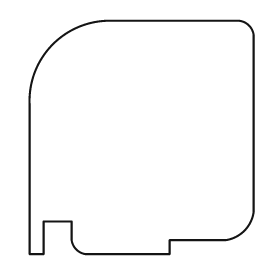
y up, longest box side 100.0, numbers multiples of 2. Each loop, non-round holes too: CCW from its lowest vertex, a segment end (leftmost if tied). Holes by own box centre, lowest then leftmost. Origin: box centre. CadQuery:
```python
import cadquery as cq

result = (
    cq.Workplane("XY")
    .moveTo(-48.0, -50.0)
    .lineTo(-42.0, -50.0)
    .lineTo(-42.0, -36.0)
    .lineTo(-30.0, -36.0)
    .lineTo(-30.0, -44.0)
    .threePointArc((-28.0, -48.0), (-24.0, -50.0))
    .lineTo(12.0, -50.0)
    .lineTo(12.0, -44.0)
    .lineTo(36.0, -44.0)
    .threePointArc((44.0, -40.0), (48.0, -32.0))
    .lineTo(48.0, 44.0)
    .threePointArc((46.0, 48.0), (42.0, 50.0))
    .lineTo(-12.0, 50.0)
    .threePointArc((-38.0, 40.0), (-48.0, 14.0))
    .close()
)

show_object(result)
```